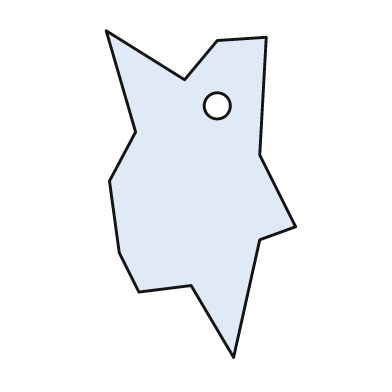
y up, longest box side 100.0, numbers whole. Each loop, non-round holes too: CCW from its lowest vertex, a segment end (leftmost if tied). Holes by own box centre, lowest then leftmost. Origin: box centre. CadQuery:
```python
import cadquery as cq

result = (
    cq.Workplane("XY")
    .moveTo(10.0, -50.0)
    .lineTo(18.0, -14.0)
    .lineTo(29.0, -10.0)
    .lineTo(18.0, 12.0)
    .lineTo(20.0, 48.0)
    .lineTo(5.0, 47.0)
    .lineTo(-5.0, 35.0)
    .lineTo(-29.0, 50.0)
    .lineTo(-20.0, 19.0)
    .lineTo(-28.0, 4.0)
    .lineTo(-25.0, -18.0)
    .lineTo(-19.0, -30.0)
    .lineTo(-3.0, -28.0)
    .close()
    .moveTo(5.0, 27.0)
    .circle(4.0)
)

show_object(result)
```